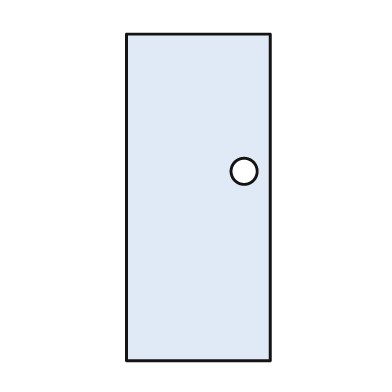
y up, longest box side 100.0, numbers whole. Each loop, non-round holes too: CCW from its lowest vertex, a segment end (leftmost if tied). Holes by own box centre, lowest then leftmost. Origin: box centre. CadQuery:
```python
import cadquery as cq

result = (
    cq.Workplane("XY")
    .moveTo(-22.0, -50.0)
    .lineTo(22.0, -50.0)
    .lineTo(22.0, 50.0)
    .lineTo(-22.0, 50.0)
    .close()
    .moveTo(14.0, 8.0)
    .circle(4.0)
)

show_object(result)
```